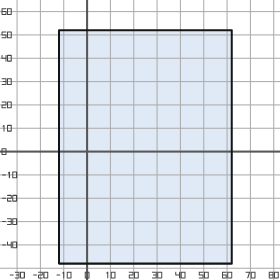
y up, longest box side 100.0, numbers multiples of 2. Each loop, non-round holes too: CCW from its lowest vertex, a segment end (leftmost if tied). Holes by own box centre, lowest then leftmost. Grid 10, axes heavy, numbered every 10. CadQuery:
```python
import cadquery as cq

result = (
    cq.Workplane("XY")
    .moveTo(-12.0, -48.0)
    .lineTo(62.0, -48.0)
    .lineTo(62.0, 52.0)
    .lineTo(-12.0, 52.0)
    .close()
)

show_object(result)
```